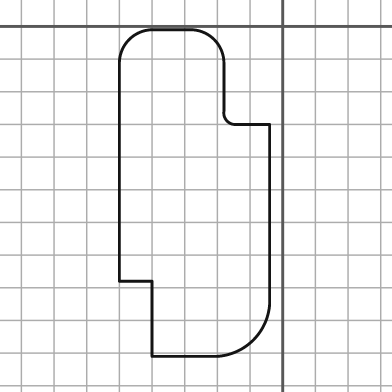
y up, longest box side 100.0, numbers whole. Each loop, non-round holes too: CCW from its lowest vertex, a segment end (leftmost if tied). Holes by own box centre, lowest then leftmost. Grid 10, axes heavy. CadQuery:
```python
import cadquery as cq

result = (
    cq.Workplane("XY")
    .moveTo(-40.0, -101.0)
    .lineTo(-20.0, -101.0)
    .threePointArc((-9.0, -96.0), (-4.0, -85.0))
    .lineTo(-4.0, -30.0)
    .lineTo(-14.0, -30.0)
    .threePointArc((-17.0, -29.0), (-18.0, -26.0))
    .lineTo(-18.0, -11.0)
    .threePointArc((-21.0, -4.0), (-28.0, -1.0))
    .lineTo(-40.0, -1.0)
    .threePointArc((-47.0, -4.0), (-50.0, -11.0))
    .lineTo(-50.0, -78.0)
    .lineTo(-40.0, -78.0)
    .close()
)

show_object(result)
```